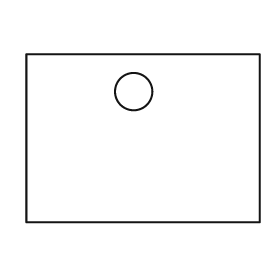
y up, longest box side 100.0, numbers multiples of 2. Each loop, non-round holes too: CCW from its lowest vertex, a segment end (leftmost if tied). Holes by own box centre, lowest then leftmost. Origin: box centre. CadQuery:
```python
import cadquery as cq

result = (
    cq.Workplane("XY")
    .moveTo(-50.0, -36.0)
    .lineTo(50.0, -36.0)
    .lineTo(50.0, 36.0)
    .lineTo(-50.0, 36.0)
    .close()
    .moveTo(-4.0, 20.0)
    .circle(8.0)
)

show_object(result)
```